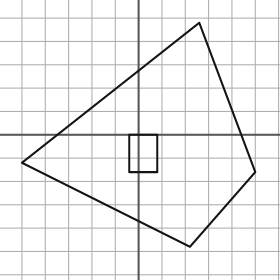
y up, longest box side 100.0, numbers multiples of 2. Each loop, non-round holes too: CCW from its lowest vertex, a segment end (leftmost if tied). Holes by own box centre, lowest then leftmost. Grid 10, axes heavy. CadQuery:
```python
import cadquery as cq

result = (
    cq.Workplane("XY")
    .moveTo(22.0, -48.0)
    .lineTo(50.0, -16.0)
    .lineTo(26.0, 48.0)
    .lineTo(-50.0, -12.0)
    .close()
    .moveTo(-4.0, -16.0)
    .lineTo(8.0, -16.0)
    .lineTo(8.0, 0.0)
    .lineTo(-4.0, 0.0)
    .close()
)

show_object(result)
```